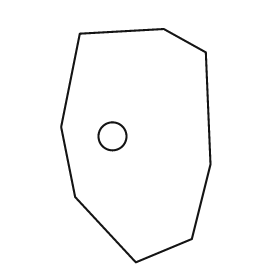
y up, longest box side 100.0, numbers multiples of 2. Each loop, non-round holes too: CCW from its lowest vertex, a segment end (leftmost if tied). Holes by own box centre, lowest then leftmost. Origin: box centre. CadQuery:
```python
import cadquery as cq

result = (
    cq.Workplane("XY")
    .moveTo(0.0, -50.0)
    .lineTo(24.0, -40.0)
    .lineTo(32.0, -8.0)
    .lineTo(30.0, 40.0)
    .lineTo(12.0, 50.0)
    .lineTo(-24.0, 48.0)
    .lineTo(-32.0, 8.0)
    .lineTo(-26.0, -22.0)
    .close()
    .moveTo(-10.0, 4.0)
    .circle(6.0)
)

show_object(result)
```